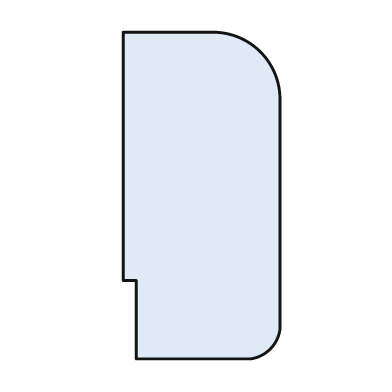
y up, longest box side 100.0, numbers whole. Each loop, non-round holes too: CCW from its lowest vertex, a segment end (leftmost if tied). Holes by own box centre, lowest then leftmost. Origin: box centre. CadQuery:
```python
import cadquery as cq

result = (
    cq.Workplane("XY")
    .moveTo(-20.0, -50.0)
    .lineTo(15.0, -50.0)
    .threePointArc((21.0, -47.0), (24.0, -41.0))
    .lineTo(24.0, 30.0)
    .threePointArc((18.0, 44.0), (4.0, 50.0))
    .lineTo(-24.0, 50.0)
    .lineTo(-24.0, -26.0)
    .lineTo(-20.0, -26.0)
    .close()
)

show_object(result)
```